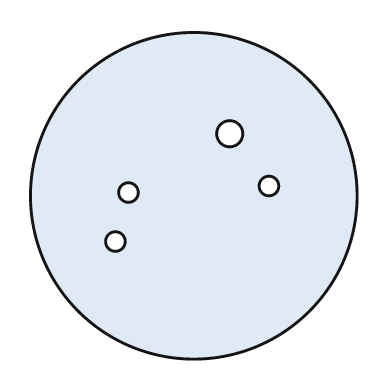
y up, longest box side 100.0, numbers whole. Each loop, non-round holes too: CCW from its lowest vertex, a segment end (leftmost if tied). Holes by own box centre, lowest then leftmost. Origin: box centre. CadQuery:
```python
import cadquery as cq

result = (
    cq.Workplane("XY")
    .moveTo(0.0, 0.0)
    .circle(50.0)
    .moveTo(-24.0, -14.0)
    .circle(3.0)
    .moveTo(-20.0, 1.0)
    .circle(3.0)
    .moveTo(23.0, 3.0)
    .circle(3.0)
    .moveTo(11.0, 19.0)
    .circle(4.0)
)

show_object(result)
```